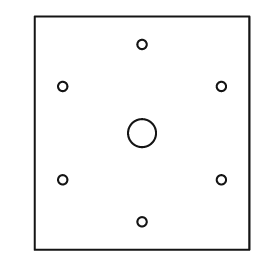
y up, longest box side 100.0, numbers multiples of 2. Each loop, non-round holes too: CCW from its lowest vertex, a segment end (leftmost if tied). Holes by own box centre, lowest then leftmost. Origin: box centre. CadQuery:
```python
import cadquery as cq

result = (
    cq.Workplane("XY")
    .moveTo(-46.0, -50.0)
    .lineTo(46.0, -50.0)
    .lineTo(46.0, 50.0)
    .lineTo(-46.0, 50.0)
    .close()
    .moveTo(0.0, -38.0)
    .circle(2.0)
    .moveTo(-34.0, -20.0)
    .circle(2.0)
    .moveTo(34.0, -20.0)
    .circle(2.0)
    .moveTo(0.0, 0.0)
    .circle(6.0)
    .moveTo(-34.0, 20.0)
    .circle(2.0)
    .moveTo(34.0, 20.0)
    .circle(2.0)
    .moveTo(0.0, 38.0)
    .circle(2.0)
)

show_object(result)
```